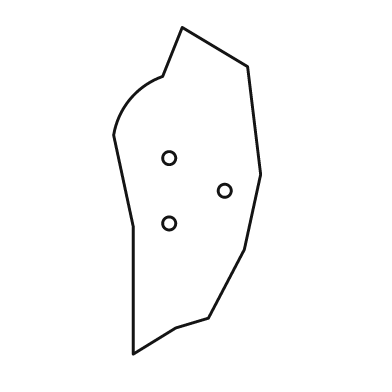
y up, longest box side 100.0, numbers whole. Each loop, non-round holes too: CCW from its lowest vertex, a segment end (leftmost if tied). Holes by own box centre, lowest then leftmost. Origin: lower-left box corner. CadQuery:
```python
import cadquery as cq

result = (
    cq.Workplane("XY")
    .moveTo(6.0, 0.0)
    .lineTo(19.0, 8.0)
    .lineTo(29.0, 11.0)
    .lineTo(40.0, 32.0)
    .lineTo(45.0, 55.0)
    .lineTo(41.0, 88.0)
    .lineTo(21.0, 100.0)
    .lineTo(15.0, 85.0)
    .threePointArc((5.0, 78.0), (0.0, 67.0))
    .lineTo(6.0, 39.0)
    .close()
    .moveTo(17.0, 40.0)
    .circle(2.0)
    .moveTo(34.0, 50.0)
    .circle(2.0)
    .moveTo(17.0, 60.0)
    .circle(2.0)
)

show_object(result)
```